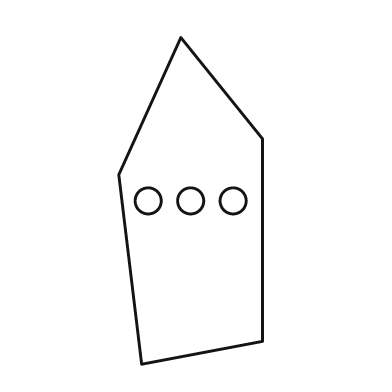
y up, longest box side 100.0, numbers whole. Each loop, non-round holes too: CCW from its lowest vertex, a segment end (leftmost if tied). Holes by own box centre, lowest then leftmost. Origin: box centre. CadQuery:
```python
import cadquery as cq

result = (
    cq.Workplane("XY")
    .moveTo(-15.0, -50.0)
    .lineTo(22.0, -43.0)
    .lineTo(22.0, 19.0)
    .lineTo(-3.0, 50.0)
    .lineTo(-22.0, 8.0)
    .close()
    .moveTo(-13.0, 0.0)
    .circle(4.0)
    .moveTo(0.0, 0.0)
    .circle(4.0)
    .moveTo(13.0, 0.0)
    .circle(4.0)
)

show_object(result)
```